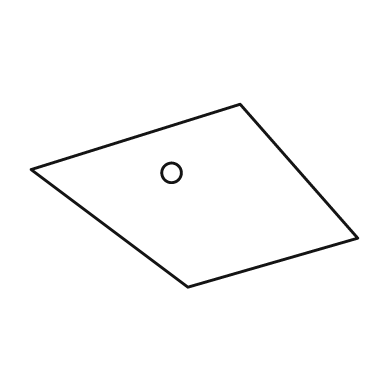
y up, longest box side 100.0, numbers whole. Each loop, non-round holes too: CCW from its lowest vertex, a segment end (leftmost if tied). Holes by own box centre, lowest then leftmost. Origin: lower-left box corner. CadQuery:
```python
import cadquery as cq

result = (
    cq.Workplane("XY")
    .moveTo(48.0, 0.0)
    .lineTo(100.0, 15.0)
    .lineTo(64.0, 56.0)
    .lineTo(0.0, 36.0)
    .close()
    .moveTo(43.0, 35.0)
    .circle(3.0)
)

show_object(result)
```